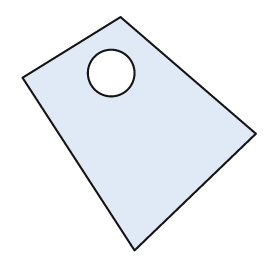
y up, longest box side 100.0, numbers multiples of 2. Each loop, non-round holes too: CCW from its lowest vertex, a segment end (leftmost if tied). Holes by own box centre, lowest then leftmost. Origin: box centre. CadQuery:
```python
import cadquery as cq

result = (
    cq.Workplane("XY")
    .moveTo(-2.0, -50.0)
    .lineTo(50.0, 0.0)
    .lineTo(-8.0, 50.0)
    .lineTo(-50.0, 24.0)
    .close()
    .moveTo(-12.0, 26.0)
    .circle(10.0)
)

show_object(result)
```